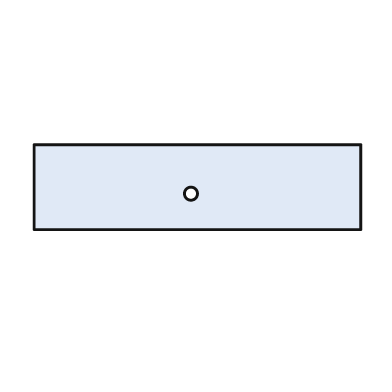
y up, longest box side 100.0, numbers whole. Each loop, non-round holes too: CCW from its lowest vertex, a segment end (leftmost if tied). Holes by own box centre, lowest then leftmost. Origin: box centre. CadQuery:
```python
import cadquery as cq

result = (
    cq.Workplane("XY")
    .moveTo(-50.0, -13.0)
    .lineTo(50.0, -13.0)
    .lineTo(50.0, 13.0)
    .lineTo(-50.0, 13.0)
    .close()
    .moveTo(-2.0, -2.0)
    .circle(2.0)
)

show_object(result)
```